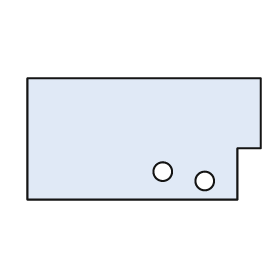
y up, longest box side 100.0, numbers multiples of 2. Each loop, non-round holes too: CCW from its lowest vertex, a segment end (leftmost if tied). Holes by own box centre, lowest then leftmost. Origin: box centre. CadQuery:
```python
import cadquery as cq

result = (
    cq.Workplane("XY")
    .moveTo(-50.0, -26.0)
    .lineTo(40.0, -26.0)
    .lineTo(40.0, -4.0)
    .lineTo(50.0, -4.0)
    .lineTo(50.0, 26.0)
    .lineTo(-50.0, 26.0)
    .close()
    .moveTo(26.0, -18.0)
    .circle(4.0)
    .moveTo(8.0, -14.0)
    .circle(4.0)
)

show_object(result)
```